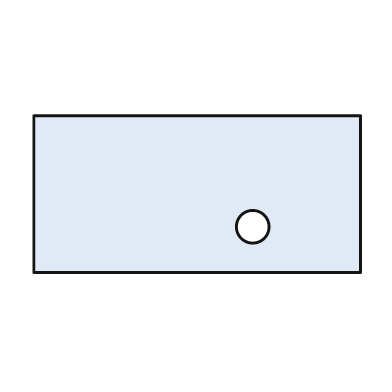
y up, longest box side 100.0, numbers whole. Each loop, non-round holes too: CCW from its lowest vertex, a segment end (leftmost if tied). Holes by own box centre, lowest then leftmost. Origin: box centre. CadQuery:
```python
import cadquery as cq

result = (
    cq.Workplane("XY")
    .moveTo(-50.0, -24.0)
    .lineTo(50.0, -24.0)
    .lineTo(50.0, 24.0)
    .lineTo(-50.0, 24.0)
    .close()
    .moveTo(17.0, -10.0)
    .circle(5.0)
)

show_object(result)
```